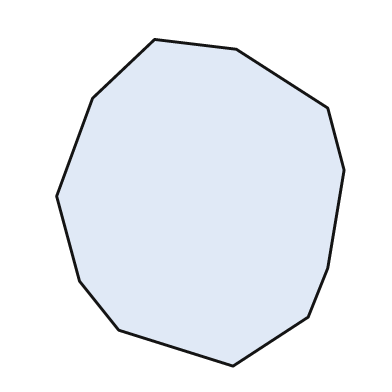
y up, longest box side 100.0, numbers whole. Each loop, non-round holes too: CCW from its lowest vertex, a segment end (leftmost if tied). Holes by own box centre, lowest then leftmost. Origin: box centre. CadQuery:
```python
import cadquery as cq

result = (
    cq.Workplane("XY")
    .moveTo(10.0, -50.0)
    .lineTo(33.0, -35.0)
    .lineTo(39.0, -20.0)
    .lineTo(44.0, 10.0)
    .lineTo(39.0, 29.0)
    .lineTo(11.0, 47.0)
    .lineTo(-14.0, 50.0)
    .lineTo(-33.0, 32.0)
    .lineTo(-44.0, 2.0)
    .lineTo(-37.0, -24.0)
    .lineTo(-25.0, -39.0)
    .close()
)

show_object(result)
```